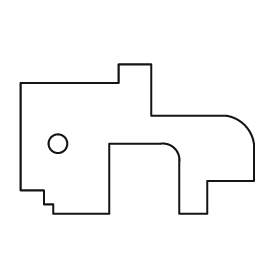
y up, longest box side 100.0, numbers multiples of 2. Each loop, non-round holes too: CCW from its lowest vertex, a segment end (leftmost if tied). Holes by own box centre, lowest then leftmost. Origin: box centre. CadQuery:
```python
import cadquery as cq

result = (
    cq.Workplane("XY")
    .moveTo(-36.0, -32.0)
    .lineTo(-12.0, -32.0)
    .lineTo(-12.0, -2.0)
    .lineTo(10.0, -2.0)
    .threePointArc((16.0, -4.0), (18.0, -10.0))
    .lineTo(18.0, -32.0)
    .lineTo(30.0, -32.0)
    .lineTo(30.0, -18.0)
    .lineTo(50.0, -18.0)
    .lineTo(50.0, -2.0)
    .threePointArc((46.0, 6.0), (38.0, 10.0))
    .lineTo(6.0, 10.0)
    .lineTo(6.0, 32.0)
    .lineTo(-8.0, 32.0)
    .lineTo(-8.0, 24.0)
    .lineTo(-50.0, 24.0)
    .lineTo(-50.0, -22.0)
    .lineTo(-40.0, -22.0)
    .lineTo(-40.0, -28.0)
    .lineTo(-36.0, -28.0)
    .close()
    .moveTo(-34.0, -2.0)
    .circle(4.0)
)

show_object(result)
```